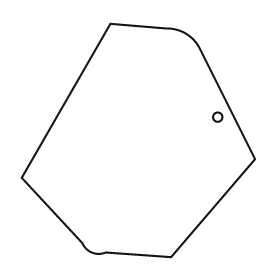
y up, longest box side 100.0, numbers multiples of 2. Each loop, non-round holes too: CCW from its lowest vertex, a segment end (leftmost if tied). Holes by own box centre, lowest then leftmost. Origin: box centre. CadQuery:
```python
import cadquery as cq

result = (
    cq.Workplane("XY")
    .moveTo(14.0, -50.0)
    .lineTo(50.0, -8.0)
    .lineTo(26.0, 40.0)
    .threePointArc((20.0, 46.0), (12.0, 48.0))
    .lineTo(-12.0, 50.0)
    .lineTo(-50.0, -16.0)
    .lineTo(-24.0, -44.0)
    .threePointArc((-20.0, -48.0), (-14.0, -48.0))
    .close()
    .moveTo(34.0, 10.0)
    .circle(2.0)
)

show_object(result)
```